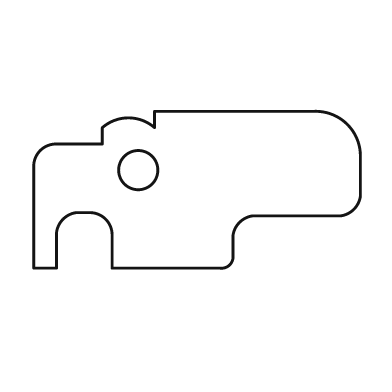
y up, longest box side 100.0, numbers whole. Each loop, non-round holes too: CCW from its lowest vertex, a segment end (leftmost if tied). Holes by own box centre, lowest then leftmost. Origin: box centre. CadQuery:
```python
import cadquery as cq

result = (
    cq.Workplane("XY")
    .moveTo(-50.0, -24.0)
    .lineTo(-43.0, -24.0)
    .lineTo(-43.0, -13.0)
    .threePointArc((-41.0, -9.0), (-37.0, -7.0))
    .lineTo(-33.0, -7.0)
    .threePointArc((-28.0, -9.0), (-26.0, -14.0))
    .lineTo(-26.0, -24.0)
    .lineTo(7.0, -24.0)
    .threePointArc((10.0, -23.0), (11.0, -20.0))
    .lineTo(11.0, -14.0)
    .threePointArc((13.0, -10.0), (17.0, -8.0))
    .lineTo(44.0, -8.0)
    .threePointArc((48.0, -6.0), (50.0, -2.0))
    .lineTo(50.0, 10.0)
    .threePointArc((46.0, 20.0), (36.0, 24.0))
    .lineTo(-13.0, 24.0)
    .lineTo(-13.0, 19.0)
    .threePointArc((-21.0, 22.0), (-29.0, 19.0))
    .lineTo(-29.0, 14.0)
    .lineTo(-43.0, 14.0)
    .threePointArc((-48.0, 12.0), (-50.0, 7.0))
    .close()
    .moveTo(-18.0, 6.0)
    .circle(6.0)
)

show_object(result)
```